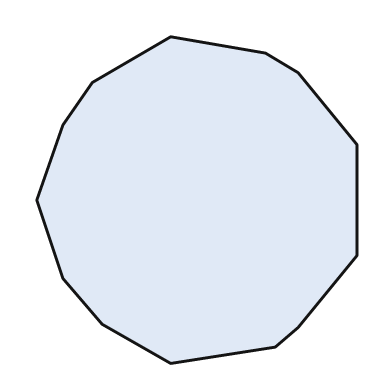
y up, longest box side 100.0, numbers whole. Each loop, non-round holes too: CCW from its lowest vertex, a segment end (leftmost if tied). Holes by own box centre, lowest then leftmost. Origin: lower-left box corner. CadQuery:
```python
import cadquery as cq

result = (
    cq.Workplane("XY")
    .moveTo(41.0, 0.0)
    .lineTo(73.0, 5.0)
    .lineTo(80.0, 11.0)
    .lineTo(98.0, 33.0)
    .lineTo(98.0, 67.0)
    .lineTo(80.0, 89.0)
    .lineTo(70.0, 95.0)
    .lineTo(41.0, 100.0)
    .lineTo(17.0, 86.0)
    .lineTo(8.0, 73.0)
    .lineTo(0.0, 50.0)
    .lineTo(8.0, 26.0)
    .lineTo(20.0, 12.0)
    .close()
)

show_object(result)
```